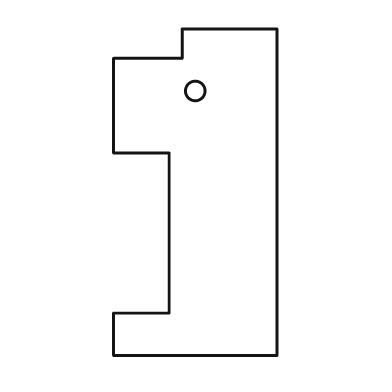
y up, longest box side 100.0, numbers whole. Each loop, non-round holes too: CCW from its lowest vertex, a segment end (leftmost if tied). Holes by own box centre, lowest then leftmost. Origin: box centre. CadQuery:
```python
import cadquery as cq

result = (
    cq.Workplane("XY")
    .moveTo(-25.0, -50.0)
    .lineTo(25.0, -50.0)
    .lineTo(25.0, 50.0)
    .lineTo(-4.0, 50.0)
    .lineTo(-4.0, 41.0)
    .lineTo(-25.0, 41.0)
    .lineTo(-25.0, 12.0)
    .lineTo(-8.0, 12.0)
    .lineTo(-8.0, -37.0)
    .lineTo(-25.0, -37.0)
    .close()
    .moveTo(0.0, 31.0)
    .circle(3.0)
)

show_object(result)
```